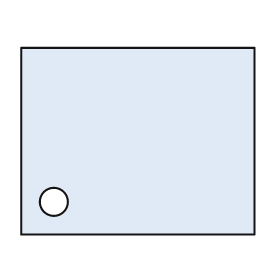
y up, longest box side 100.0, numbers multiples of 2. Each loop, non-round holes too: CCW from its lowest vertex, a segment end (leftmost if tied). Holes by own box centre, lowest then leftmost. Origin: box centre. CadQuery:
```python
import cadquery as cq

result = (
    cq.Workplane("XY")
    .moveTo(-50.0, -40.0)
    .lineTo(50.0, -40.0)
    .lineTo(50.0, 40.0)
    .lineTo(-50.0, 40.0)
    .close()
    .moveTo(-36.0, -26.0)
    .circle(6.0)
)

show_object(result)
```